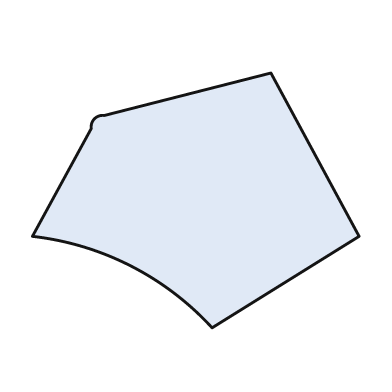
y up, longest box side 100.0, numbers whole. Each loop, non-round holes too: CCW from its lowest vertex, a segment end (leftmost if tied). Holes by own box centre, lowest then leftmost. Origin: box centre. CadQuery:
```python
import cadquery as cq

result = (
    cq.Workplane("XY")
    .moveTo(5.0, -39.0)
    .lineTo(50.0, -11.0)
    .lineTo(23.0, 39.0)
    .lineTo(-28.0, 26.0)
    .threePointArc((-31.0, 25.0), (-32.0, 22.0))
    .lineTo(-50.0, -11.0)
    .threePointArc((-20.0, -20.0), (5.0, -39.0))
    .close()
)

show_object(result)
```